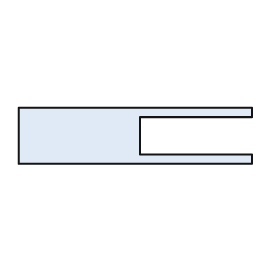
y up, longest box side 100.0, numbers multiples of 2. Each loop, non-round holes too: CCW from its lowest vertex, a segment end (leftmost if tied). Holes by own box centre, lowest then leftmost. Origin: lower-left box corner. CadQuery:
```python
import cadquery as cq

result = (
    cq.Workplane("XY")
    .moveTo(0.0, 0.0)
    .lineTo(100.0, 0.0)
    .lineTo(100.0, 4.0)
    .lineTo(52.0, 4.0)
    .lineTo(52.0, 20.0)
    .lineTo(100.0, 20.0)
    .lineTo(100.0, 24.0)
    .lineTo(0.0, 24.0)
    .close()
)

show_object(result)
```